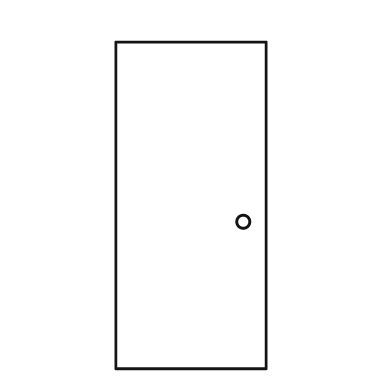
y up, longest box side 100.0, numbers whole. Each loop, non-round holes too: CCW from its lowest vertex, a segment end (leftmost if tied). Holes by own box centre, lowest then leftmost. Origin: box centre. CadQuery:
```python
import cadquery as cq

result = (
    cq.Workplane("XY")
    .moveTo(-23.0, -50.0)
    .lineTo(23.0, -50.0)
    .lineTo(23.0, 50.0)
    .lineTo(-23.0, 50.0)
    .close()
    .moveTo(16.0, -5.0)
    .circle(2.0)
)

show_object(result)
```